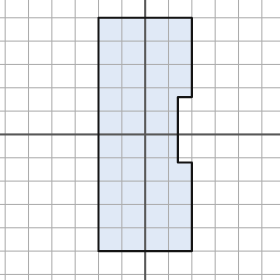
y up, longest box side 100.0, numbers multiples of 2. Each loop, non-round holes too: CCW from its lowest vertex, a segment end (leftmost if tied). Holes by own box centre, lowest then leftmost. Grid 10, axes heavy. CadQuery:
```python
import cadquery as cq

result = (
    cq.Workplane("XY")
    .moveTo(-20.0, -50.0)
    .lineTo(20.0, -50.0)
    .lineTo(20.0, -12.0)
    .lineTo(14.0, -12.0)
    .lineTo(14.0, 16.0)
    .lineTo(20.0, 16.0)
    .lineTo(20.0, 50.0)
    .lineTo(-20.0, 50.0)
    .close()
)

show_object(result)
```